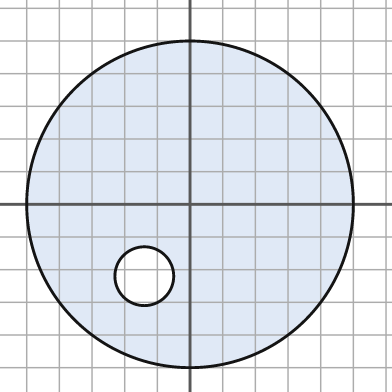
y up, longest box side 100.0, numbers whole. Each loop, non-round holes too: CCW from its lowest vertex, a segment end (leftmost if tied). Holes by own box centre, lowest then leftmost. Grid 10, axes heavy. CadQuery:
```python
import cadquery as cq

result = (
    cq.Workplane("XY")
    .moveTo(0.0, 0.0)
    .circle(50.0)
    .moveTo(-14.0, -22.0)
    .circle(9.0)
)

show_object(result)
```